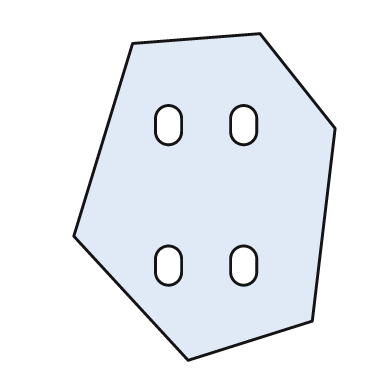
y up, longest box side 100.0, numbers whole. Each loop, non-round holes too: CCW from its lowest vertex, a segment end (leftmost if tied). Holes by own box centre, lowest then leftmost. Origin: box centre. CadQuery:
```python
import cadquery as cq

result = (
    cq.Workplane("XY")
    .moveTo(-5.0, -50.0)
    .lineTo(33.0, -38.0)
    .lineTo(40.0, 21.0)
    .lineTo(17.0, 50.0)
    .lineTo(-22.0, 47.0)
    .lineTo(-40.0, -12.0)
    .close()
    .moveTo(-15.0, -23.0)
    .threePointArc((-11.0, -27.0), (-7.0, -23.0))
    .lineTo(-7.0, -19.0)
    .threePointArc((-11.0, -15.0), (-15.0, -19.0))
    .close()
    .moveTo(8.0, -23.0)
    .threePointArc((12.0, -27.0), (16.0, -23.0))
    .lineTo(16.0, -19.0)
    .threePointArc((12.0, -15.0), (8.0, -19.0))
    .close()
    .moveTo(-15.0, 20.0)
    .threePointArc((-11.0, 16.0), (-7.0, 20.0))
    .lineTo(-7.0, 24.0)
    .threePointArc((-11.0, 28.0), (-15.0, 24.0))
    .close()
    .moveTo(8.0, 20.0)
    .threePointArc((12.0, 16.0), (16.0, 20.0))
    .lineTo(16.0, 24.0)
    .threePointArc((12.0, 28.0), (8.0, 24.0))
    .close()
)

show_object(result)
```